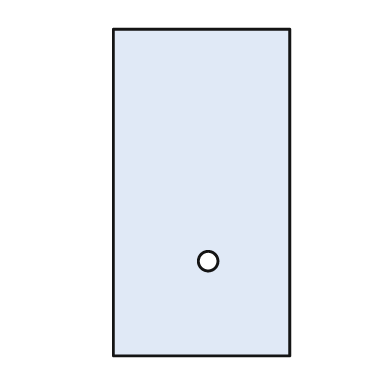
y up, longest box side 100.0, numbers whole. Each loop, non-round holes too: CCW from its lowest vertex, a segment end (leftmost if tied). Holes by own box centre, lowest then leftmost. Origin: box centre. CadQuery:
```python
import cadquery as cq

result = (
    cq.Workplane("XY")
    .moveTo(-27.0, -50.0)
    .lineTo(27.0, -50.0)
    .lineTo(27.0, 50.0)
    .lineTo(-27.0, 50.0)
    .close()
    .moveTo(2.0, -21.0)
    .circle(3.0)
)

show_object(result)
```